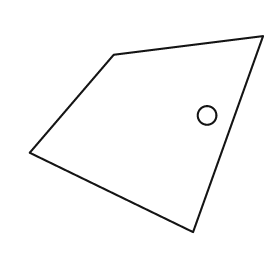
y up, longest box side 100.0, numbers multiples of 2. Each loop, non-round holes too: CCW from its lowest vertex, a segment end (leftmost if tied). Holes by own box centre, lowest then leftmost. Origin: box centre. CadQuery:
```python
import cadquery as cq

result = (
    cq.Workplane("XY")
    .moveTo(20.0, -42.0)
    .lineTo(50.0, 42.0)
    .lineTo(-14.0, 34.0)
    .lineTo(-50.0, -8.0)
    .close()
    .moveTo(26.0, 8.0)
    .circle(4.0)
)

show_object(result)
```